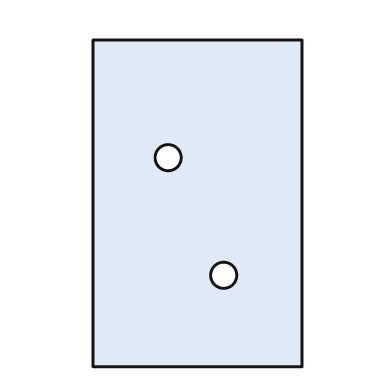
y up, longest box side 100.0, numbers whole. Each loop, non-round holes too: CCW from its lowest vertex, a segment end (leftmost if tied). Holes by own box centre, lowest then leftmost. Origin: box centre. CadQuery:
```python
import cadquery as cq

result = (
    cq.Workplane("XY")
    .moveTo(-32.0, -50.0)
    .lineTo(32.0, -50.0)
    .lineTo(32.0, 50.0)
    .lineTo(-32.0, 50.0)
    .close()
    .moveTo(8.0, -22.0)
    .circle(4.0)
    .moveTo(-9.0, 14.0)
    .circle(4.0)
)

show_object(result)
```